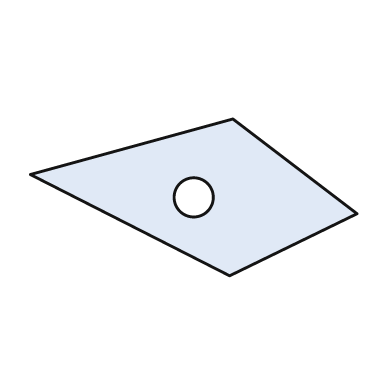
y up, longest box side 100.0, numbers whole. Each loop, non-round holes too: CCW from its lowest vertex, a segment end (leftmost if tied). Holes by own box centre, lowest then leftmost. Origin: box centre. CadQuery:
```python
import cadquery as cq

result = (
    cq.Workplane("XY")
    .moveTo(11.0, -24.0)
    .lineTo(50.0, -5.0)
    .lineTo(12.0, 24.0)
    .lineTo(-50.0, 7.0)
    .close()
    .moveTo(0.0, 0.0)
    .circle(6.0)
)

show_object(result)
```